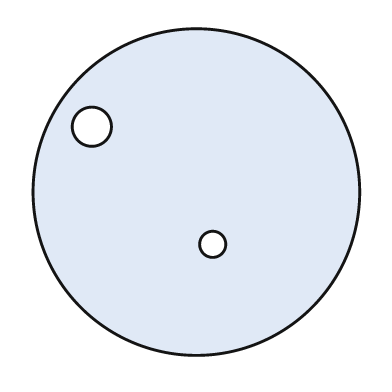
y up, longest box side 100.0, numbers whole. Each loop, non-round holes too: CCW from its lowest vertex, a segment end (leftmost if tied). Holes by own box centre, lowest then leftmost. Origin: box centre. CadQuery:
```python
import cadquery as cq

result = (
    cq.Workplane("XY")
    .moveTo(0.0, 0.0)
    .circle(50.0)
    .moveTo(5.0, -16.0)
    .circle(4.0)
    .moveTo(-32.0, 20.0)
    .circle(6.0)
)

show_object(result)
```